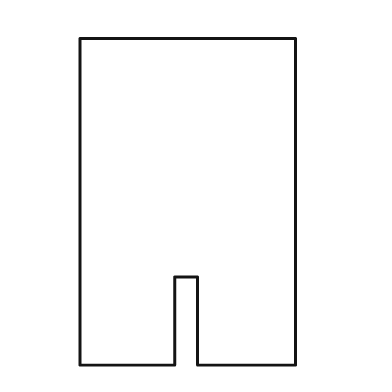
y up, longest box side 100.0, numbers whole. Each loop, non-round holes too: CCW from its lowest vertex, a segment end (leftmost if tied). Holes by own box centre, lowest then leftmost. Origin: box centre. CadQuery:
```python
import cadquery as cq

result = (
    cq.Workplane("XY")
    .moveTo(-33.0, -50.0)
    .lineTo(-4.0, -50.0)
    .lineTo(-4.0, -23.0)
    .lineTo(3.0, -23.0)
    .lineTo(3.0, -50.0)
    .lineTo(33.0, -50.0)
    .lineTo(33.0, 50.0)
    .lineTo(-33.0, 50.0)
    .close()
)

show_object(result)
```